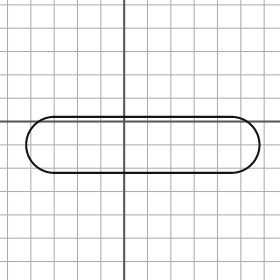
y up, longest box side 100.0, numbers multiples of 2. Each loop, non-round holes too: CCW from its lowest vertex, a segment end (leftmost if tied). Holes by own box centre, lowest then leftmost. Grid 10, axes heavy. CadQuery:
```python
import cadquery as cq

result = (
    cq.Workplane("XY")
    .moveTo(-30.0, -22.0)
    .lineTo(46.0, -22.0)
    .threePointArc((58.0, -10.0), (46.0, 2.0))
    .lineTo(-30.0, 2.0)
    .threePointArc((-42.0, -10.0), (-30.0, -22.0))
    .close()
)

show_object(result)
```